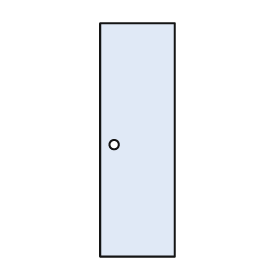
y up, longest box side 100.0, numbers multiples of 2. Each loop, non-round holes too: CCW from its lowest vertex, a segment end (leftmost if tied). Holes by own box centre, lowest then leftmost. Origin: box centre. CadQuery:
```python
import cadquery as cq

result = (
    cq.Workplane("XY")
    .moveTo(-16.0, -50.0)
    .lineTo(16.0, -50.0)
    .lineTo(16.0, 50.0)
    .lineTo(-16.0, 50.0)
    .close()
    .moveTo(-10.0, -2.0)
    .circle(2.0)
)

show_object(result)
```